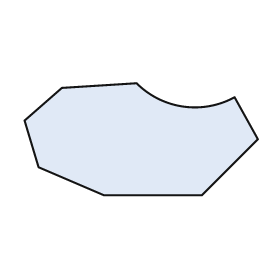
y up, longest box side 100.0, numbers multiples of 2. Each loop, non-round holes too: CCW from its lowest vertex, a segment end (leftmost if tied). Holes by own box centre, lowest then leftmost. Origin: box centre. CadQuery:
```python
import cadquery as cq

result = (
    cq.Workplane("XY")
    .moveTo(-16.0, -24.0)
    .lineTo(26.0, -24.0)
    .lineTo(50.0, 0.0)
    .lineTo(40.0, 18.0)
    .threePointArc((18.0, 14.0), (-2.0, 24.0))
    .lineTo(-34.0, 22.0)
    .lineTo(-50.0, 8.0)
    .lineTo(-44.0, -12.0)
    .close()
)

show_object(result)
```